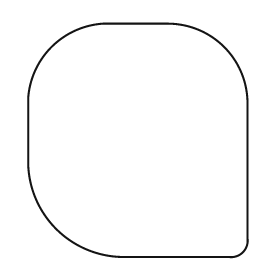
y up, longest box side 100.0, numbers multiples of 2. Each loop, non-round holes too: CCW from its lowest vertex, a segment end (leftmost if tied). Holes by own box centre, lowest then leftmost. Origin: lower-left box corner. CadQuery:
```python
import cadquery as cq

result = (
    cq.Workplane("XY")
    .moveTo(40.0, 0.0)
    .lineTo(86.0, 0.0)
    .threePointArc((92.0, 2.0), (94.0, 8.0))
    .lineTo(94.0, 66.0)
    .threePointArc((84.0, 90.0), (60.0, 100.0))
    .lineTo(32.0, 100.0)
    .threePointArc((10.0, 90.0), (0.0, 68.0))
    .lineTo(0.0, 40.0)
    .threePointArc((12.0, 12.0), (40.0, 0.0))
    .close()
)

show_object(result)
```